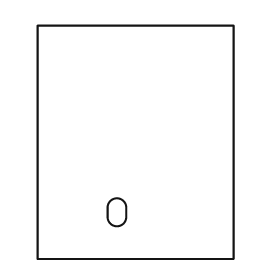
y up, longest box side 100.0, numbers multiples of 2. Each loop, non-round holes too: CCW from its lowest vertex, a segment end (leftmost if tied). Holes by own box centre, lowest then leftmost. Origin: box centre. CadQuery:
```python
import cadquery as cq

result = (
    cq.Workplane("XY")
    .moveTo(-42.0, -50.0)
    .lineTo(42.0, -50.0)
    .lineTo(42.0, 50.0)
    .lineTo(-42.0, 50.0)
    .close()
    .moveTo(-12.0, -32.0)
    .threePointArc((-8.0, -36.0), (-4.0, -32.0))
    .lineTo(-4.0, -28.0)
    .threePointArc((-8.0, -24.0), (-12.0, -28.0))
    .close()
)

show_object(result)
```